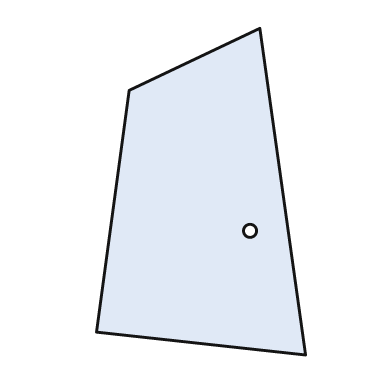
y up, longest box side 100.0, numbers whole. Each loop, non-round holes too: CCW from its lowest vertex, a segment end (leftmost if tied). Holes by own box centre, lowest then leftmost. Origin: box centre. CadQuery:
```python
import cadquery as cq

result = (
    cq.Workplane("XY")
    .moveTo(32.0, -50.0)
    .lineTo(18.0, 50.0)
    .lineTo(-22.0, 31.0)
    .lineTo(-32.0, -43.0)
    .close()
    .moveTo(15.0, -12.0)
    .circle(2.0)
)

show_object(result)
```